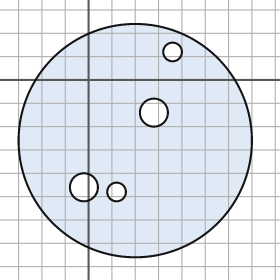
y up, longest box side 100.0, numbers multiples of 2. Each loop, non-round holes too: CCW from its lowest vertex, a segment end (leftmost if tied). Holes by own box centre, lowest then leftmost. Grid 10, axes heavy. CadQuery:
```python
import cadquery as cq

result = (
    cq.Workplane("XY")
    .moveTo(20.0, -26.0)
    .circle(50.0)
    .moveTo(12.0, -48.0)
    .circle(4.0)
    .moveTo(-2.0, -46.0)
    .circle(6.0)
    .moveTo(28.0, -14.0)
    .circle(6.0)
    .moveTo(36.0, 12.0)
    .circle(4.0)
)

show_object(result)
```